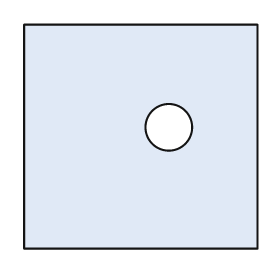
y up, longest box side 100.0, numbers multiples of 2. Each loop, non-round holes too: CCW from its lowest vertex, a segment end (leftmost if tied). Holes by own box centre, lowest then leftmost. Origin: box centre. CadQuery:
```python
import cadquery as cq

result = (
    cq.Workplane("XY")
    .moveTo(-50.0, -48.0)
    .lineTo(50.0, -48.0)
    .lineTo(50.0, 48.0)
    .lineTo(-50.0, 48.0)
    .close()
    .moveTo(12.0, 4.0)
    .circle(10.0)
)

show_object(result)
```